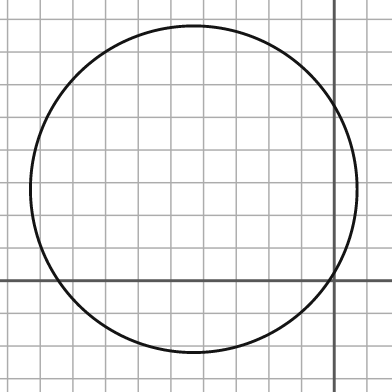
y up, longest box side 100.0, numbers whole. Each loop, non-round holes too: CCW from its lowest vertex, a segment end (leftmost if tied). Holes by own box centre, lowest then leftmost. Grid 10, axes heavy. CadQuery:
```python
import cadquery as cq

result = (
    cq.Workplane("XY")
    .moveTo(-43.0, 28.0)
    .circle(50.0)
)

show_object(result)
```